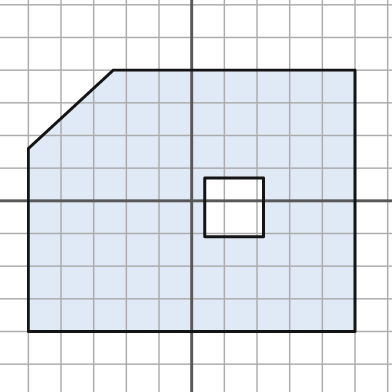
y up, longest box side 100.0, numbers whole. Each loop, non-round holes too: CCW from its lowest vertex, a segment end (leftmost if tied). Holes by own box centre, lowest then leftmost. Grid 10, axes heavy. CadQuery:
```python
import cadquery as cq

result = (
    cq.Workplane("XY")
    .moveTo(-50.0, -40.0)
    .lineTo(50.0, -40.0)
    .lineTo(50.0, 40.0)
    .lineTo(-24.0, 40.0)
    .lineTo(-50.0, 16.0)
    .close()
    .moveTo(4.0, -11.0)
    .lineTo(22.0, -11.0)
    .lineTo(22.0, 7.0)
    .lineTo(4.0, 7.0)
    .close()
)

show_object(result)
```